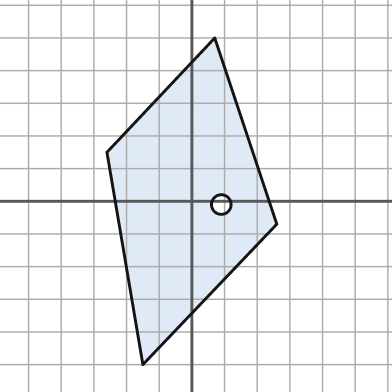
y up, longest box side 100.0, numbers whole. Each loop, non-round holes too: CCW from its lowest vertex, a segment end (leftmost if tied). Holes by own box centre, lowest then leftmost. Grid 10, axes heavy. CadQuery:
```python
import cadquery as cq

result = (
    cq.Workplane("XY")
    .moveTo(-15.0, -50.0)
    .lineTo(26.0, -7.0)
    .lineTo(7.0, 50.0)
    .lineTo(-26.0, 15.0)
    .close()
    .moveTo(9.0, -1.0)
    .circle(3.0)
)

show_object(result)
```